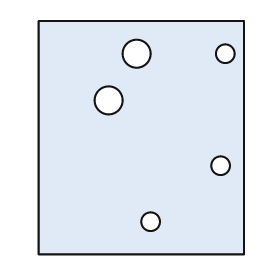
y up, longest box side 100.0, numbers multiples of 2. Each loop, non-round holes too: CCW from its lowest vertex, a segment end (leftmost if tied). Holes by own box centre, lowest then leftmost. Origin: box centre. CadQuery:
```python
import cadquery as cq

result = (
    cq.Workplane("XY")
    .moveTo(-44.0, -50.0)
    .lineTo(44.0, -50.0)
    .lineTo(44.0, 50.0)
    .lineTo(-44.0, 50.0)
    .close()
    .moveTo(4.0, -36.0)
    .circle(4.0)
    .moveTo(34.0, -12.0)
    .circle(4.0)
    .moveTo(-14.0, 16.0)
    .circle(6.0)
    .moveTo(-2.0, 36.0)
    .circle(6.0)
    .moveTo(36.0, 36.0)
    .circle(4.0)
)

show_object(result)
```